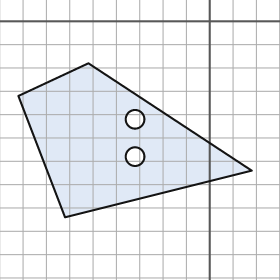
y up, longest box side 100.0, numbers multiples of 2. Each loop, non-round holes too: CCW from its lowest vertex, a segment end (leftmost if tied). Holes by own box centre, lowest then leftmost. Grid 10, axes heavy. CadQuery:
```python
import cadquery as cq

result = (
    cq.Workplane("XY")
    .moveTo(-62.0, -84.0)
    .lineTo(18.0, -64.0)
    .lineTo(-52.0, -18.0)
    .lineTo(-82.0, -32.0)
    .close()
    .moveTo(-32.0, -58.0)
    .circle(4.0)
    .moveTo(-32.0, -42.0)
    .circle(4.0)
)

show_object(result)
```